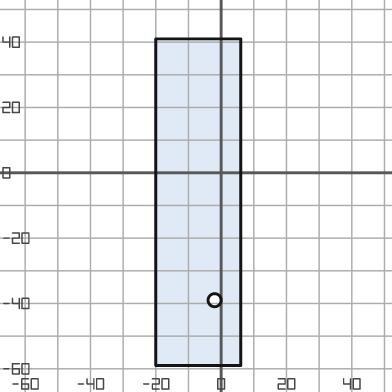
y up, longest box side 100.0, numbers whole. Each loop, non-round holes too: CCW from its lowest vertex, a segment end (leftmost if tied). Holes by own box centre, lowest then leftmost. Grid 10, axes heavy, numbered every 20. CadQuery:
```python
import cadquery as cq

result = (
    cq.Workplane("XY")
    .moveTo(-20.0, -59.0)
    .lineTo(6.0, -59.0)
    .lineTo(6.0, 41.0)
    .lineTo(-20.0, 41.0)
    .close()
    .moveTo(-2.0, -39.0)
    .circle(2.0)
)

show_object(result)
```